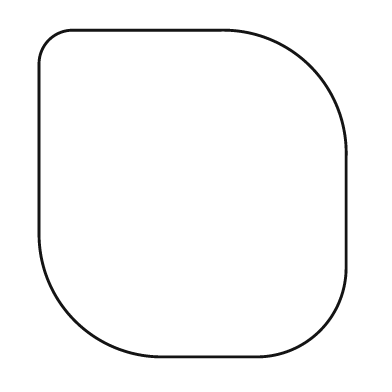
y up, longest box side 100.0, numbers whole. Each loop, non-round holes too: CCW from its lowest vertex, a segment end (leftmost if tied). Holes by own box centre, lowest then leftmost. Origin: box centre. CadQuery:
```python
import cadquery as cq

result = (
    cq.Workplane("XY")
    .moveTo(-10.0, -50.0)
    .lineTo(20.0, -50.0)
    .threePointArc((39.0, -42.0), (47.0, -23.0))
    .lineTo(47.0, 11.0)
    .threePointArc((36.0, 39.0), (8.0, 50.0))
    .lineTo(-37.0, 50.0)
    .threePointArc((-44.0, 47.0), (-47.0, 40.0))
    .lineTo(-47.0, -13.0)
    .threePointArc((-36.0, -39.0), (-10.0, -50.0))
    .close()
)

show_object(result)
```